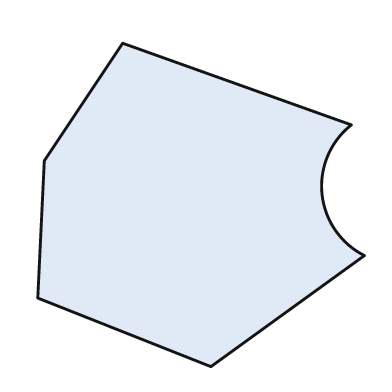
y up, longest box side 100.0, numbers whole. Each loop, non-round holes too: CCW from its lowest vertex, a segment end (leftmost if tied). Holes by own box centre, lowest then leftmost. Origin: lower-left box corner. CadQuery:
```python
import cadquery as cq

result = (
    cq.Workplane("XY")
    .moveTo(53.0, 0.0)
    .lineTo(100.0, 34.0)
    .threePointArc((87.0, 53.0), (96.0, 74.0))
    .lineTo(26.0, 99.0)
    .lineTo(2.0, 63.0)
    .lineTo(0.0, 21.0)
    .close()
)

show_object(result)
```